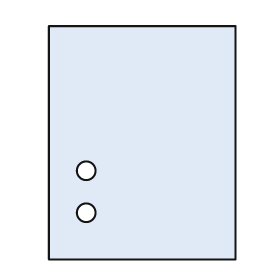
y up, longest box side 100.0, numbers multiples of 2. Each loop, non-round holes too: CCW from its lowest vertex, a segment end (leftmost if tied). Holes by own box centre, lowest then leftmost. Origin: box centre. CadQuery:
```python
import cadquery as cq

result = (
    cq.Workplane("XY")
    .moveTo(-40.0, -50.0)
    .lineTo(40.0, -50.0)
    .lineTo(40.0, 50.0)
    .lineTo(-40.0, 50.0)
    .close()
    .moveTo(-24.0, -30.0)
    .circle(4.0)
    .moveTo(-24.0, -12.0)
    .circle(4.0)
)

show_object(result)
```